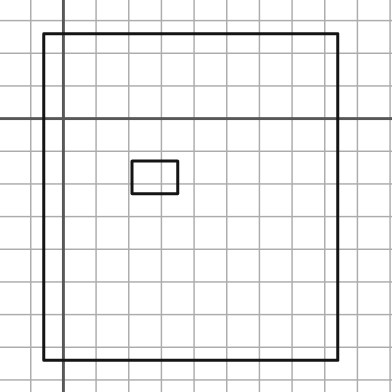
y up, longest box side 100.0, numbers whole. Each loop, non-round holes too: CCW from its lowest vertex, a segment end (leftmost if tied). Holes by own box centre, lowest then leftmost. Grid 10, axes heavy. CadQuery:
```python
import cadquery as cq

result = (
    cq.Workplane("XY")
    .moveTo(-6.0, -74.0)
    .lineTo(84.0, -74.0)
    .lineTo(84.0, 26.0)
    .lineTo(-6.0, 26.0)
    .close()
    .moveTo(21.0, -23.0)
    .lineTo(35.0, -23.0)
    .lineTo(35.0, -13.0)
    .lineTo(21.0, -13.0)
    .close()
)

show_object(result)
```